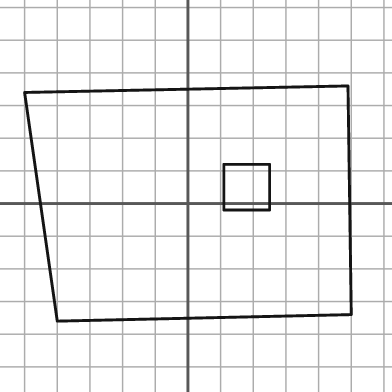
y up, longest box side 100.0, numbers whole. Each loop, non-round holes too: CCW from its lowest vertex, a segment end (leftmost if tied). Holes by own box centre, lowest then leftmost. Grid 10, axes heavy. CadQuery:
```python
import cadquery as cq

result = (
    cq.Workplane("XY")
    .moveTo(-40.0, -36.0)
    .lineTo(50.0, -34.0)
    .lineTo(49.0, 36.0)
    .lineTo(-50.0, 34.0)
    .close()
    .moveTo(11.0, -2.0)
    .lineTo(25.0, -2.0)
    .lineTo(25.0, 12.0)
    .lineTo(11.0, 12.0)
    .close()
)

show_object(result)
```